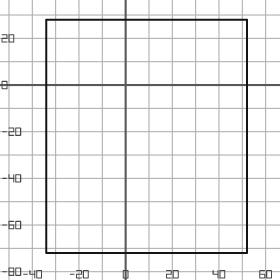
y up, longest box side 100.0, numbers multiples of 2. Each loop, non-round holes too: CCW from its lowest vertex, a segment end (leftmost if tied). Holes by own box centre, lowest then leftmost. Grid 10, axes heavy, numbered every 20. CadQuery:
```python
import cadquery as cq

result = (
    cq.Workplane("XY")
    .moveTo(-34.0, -72.0)
    .lineTo(52.0, -72.0)
    .lineTo(52.0, 28.0)
    .lineTo(-34.0, 28.0)
    .close()
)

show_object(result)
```